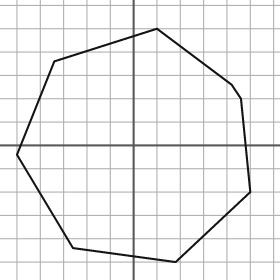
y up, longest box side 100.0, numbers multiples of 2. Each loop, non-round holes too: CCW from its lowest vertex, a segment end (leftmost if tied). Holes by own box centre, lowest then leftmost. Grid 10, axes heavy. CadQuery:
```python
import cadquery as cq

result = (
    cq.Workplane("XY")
    .moveTo(18.0, -50.0)
    .lineTo(50.0, -20.0)
    .lineTo(46.0, 20.0)
    .lineTo(42.0, 26.0)
    .lineTo(10.0, 50.0)
    .lineTo(-34.0, 36.0)
    .lineTo(-50.0, -4.0)
    .lineTo(-26.0, -44.0)
    .close()
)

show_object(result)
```